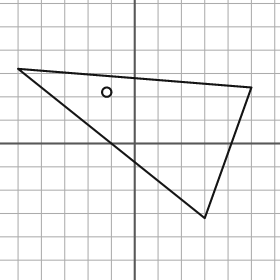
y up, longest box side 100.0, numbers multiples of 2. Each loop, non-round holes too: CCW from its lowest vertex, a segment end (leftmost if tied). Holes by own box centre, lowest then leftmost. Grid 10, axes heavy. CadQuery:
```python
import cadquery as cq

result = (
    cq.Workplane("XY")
    .moveTo(30.0, -32.0)
    .lineTo(50.0, 24.0)
    .lineTo(-50.0, 32.0)
    .close()
    .moveTo(-12.0, 22.0)
    .circle(2.0)
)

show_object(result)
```